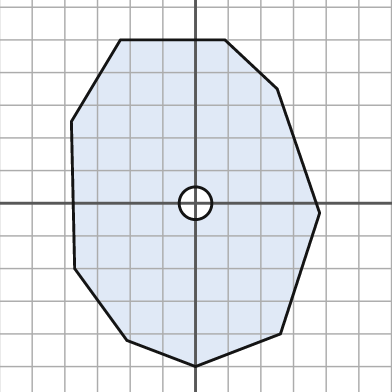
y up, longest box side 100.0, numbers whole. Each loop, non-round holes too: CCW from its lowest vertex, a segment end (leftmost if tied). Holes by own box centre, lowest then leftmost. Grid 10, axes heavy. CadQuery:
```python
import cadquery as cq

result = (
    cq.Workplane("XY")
    .moveTo(0.0, -50.0)
    .lineTo(26.0, -40.0)
    .lineTo(38.0, -3.0)
    .lineTo(25.0, 35.0)
    .lineTo(9.0, 50.0)
    .lineTo(-23.0, 50.0)
    .lineTo(-38.0, 25.0)
    .lineTo(-37.0, -20.0)
    .lineTo(-21.0, -42.0)
    .close()
    .moveTo(0.0, 0.0)
    .circle(5.0)
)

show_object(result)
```